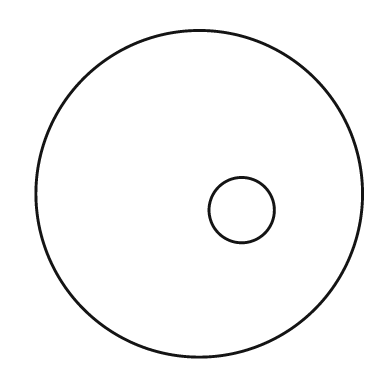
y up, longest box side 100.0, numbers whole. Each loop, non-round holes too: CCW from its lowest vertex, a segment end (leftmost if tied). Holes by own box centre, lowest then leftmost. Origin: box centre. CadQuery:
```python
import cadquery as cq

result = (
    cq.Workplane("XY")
    .moveTo(0.0, 0.0)
    .circle(50.0)
    .moveTo(13.0, -5.0)
    .circle(10.0)
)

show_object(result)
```